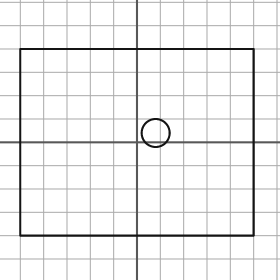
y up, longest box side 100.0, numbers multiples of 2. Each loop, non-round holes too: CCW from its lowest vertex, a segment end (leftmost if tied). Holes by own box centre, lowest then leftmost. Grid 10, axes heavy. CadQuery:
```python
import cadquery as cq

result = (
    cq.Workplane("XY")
    .moveTo(-50.0, -40.0)
    .lineTo(50.0, -40.0)
    .lineTo(50.0, 40.0)
    .lineTo(-50.0, 40.0)
    .close()
    .moveTo(8.0, 4.0)
    .circle(6.0)
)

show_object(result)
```